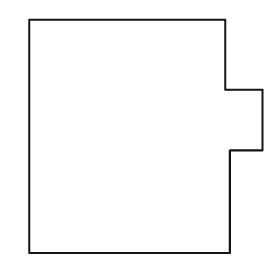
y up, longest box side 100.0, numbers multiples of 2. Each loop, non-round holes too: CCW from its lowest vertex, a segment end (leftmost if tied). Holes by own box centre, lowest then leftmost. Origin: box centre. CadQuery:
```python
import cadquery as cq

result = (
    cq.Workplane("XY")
    .moveTo(-50.0, -50.0)
    .lineTo(36.0, -50.0)
    .lineTo(36.0, -6.0)
    .lineTo(50.0, -6.0)
    .lineTo(50.0, 20.0)
    .lineTo(34.0, 20.0)
    .lineTo(34.0, 50.0)
    .lineTo(-50.0, 50.0)
    .close()
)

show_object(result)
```